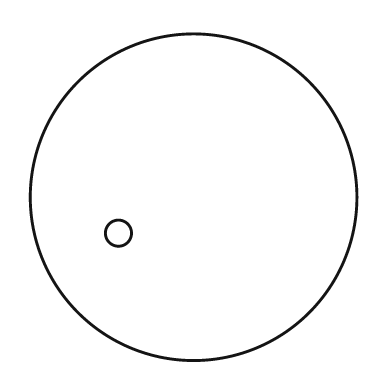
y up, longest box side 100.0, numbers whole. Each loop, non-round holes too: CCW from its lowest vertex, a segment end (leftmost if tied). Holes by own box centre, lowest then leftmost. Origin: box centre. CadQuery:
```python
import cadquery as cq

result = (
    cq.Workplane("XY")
    .moveTo(0.0, 0.0)
    .circle(50.0)
    .moveTo(-23.0, -11.0)
    .circle(4.0)
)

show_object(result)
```